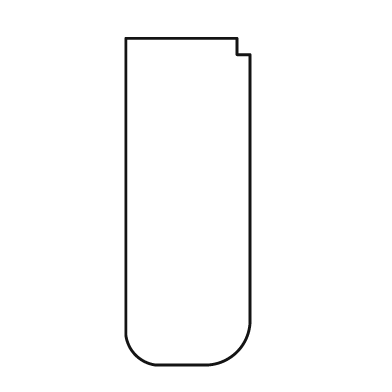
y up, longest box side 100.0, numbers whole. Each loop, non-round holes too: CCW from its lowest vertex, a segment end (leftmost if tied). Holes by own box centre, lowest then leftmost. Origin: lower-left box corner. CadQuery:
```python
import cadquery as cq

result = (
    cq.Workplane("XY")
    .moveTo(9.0, 0.0)
    .lineTo(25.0, 0.0)
    .threePointArc((34.0, 4.0), (38.0, 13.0))
    .lineTo(38.0, 95.0)
    .lineTo(34.0, 95.0)
    .lineTo(34.0, 100.0)
    .lineTo(0.0, 100.0)
    .lineTo(0.0, 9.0)
    .threePointArc((3.0, 3.0), (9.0, 0.0))
    .close()
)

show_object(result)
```